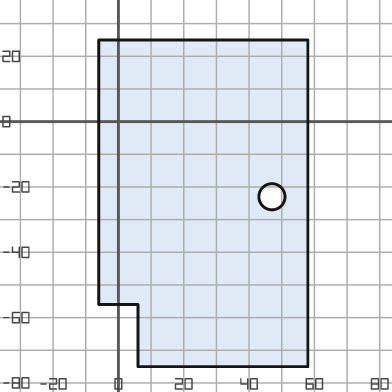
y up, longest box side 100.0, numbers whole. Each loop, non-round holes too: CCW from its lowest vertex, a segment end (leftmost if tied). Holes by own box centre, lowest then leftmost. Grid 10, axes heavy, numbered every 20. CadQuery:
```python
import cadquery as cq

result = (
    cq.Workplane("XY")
    .moveTo(6.0, -75.0)
    .lineTo(58.0, -75.0)
    .lineTo(58.0, 25.0)
    .lineTo(-6.0, 25.0)
    .lineTo(-6.0, -56.0)
    .lineTo(6.0, -56.0)
    .close()
    .moveTo(47.0, -23.0)
    .circle(4.0)
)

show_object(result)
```